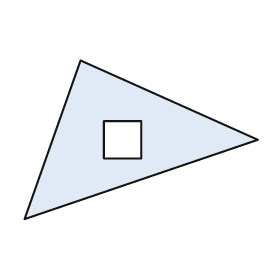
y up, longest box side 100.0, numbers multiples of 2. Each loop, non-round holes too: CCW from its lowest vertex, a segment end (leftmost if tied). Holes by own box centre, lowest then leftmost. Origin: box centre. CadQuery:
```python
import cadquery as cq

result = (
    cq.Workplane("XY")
    .moveTo(-50.0, -34.0)
    .lineTo(50.0, 0.0)
    .lineTo(-26.0, 34.0)
    .close()
    .moveTo(-16.0, -8.0)
    .lineTo(0.0, -8.0)
    .lineTo(0.0, 8.0)
    .lineTo(-16.0, 8.0)
    .close()
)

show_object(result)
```